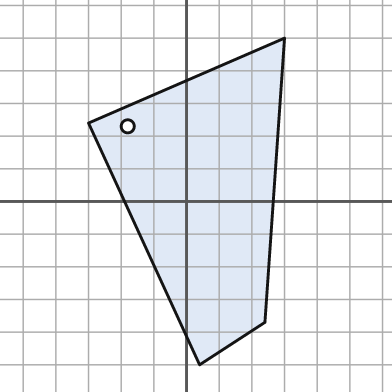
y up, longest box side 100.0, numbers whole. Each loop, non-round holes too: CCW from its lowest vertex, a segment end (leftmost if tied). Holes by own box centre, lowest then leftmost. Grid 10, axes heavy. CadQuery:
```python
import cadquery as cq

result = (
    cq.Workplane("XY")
    .moveTo(4.0, -50.0)
    .lineTo(24.0, -37.0)
    .lineTo(30.0, 50.0)
    .lineTo(-30.0, 24.0)
    .close()
    .moveTo(-18.0, 23.0)
    .circle(2.0)
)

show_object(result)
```